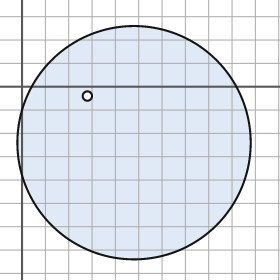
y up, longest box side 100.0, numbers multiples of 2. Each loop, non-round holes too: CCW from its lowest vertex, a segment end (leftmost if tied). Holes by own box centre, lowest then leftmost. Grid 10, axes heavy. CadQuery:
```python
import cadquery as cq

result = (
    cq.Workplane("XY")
    .moveTo(48.0, -24.0)
    .circle(50.0)
    .moveTo(28.0, -4.0)
    .circle(2.0)
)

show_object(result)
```